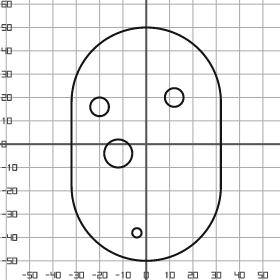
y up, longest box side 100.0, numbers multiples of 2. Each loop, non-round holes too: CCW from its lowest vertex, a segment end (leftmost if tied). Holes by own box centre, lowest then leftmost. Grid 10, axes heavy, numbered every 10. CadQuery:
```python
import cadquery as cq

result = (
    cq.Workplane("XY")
    .moveTo(-32.0, -18.0)
    .threePointArc((0.0, -50.0), (32.0, -18.0))
    .lineTo(32.0, 18.0)
    .threePointArc((0.0, 50.0), (-32.0, 18.0))
    .close()
    .moveTo(-4.0, -38.0)
    .circle(2.0)
    .moveTo(-12.0, -4.0)
    .circle(6.0)
    .moveTo(-20.0, 16.0)
    .circle(4.0)
    .moveTo(12.0, 20.0)
    .circle(4.0)
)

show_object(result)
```